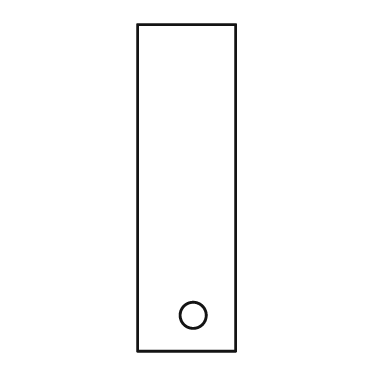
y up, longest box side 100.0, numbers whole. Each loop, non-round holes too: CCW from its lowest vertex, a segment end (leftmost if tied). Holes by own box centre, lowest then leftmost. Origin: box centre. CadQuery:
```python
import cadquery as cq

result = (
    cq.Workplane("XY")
    .moveTo(-15.0, -50.0)
    .lineTo(15.0, -50.0)
    .lineTo(15.0, 50.0)
    .lineTo(-15.0, 50.0)
    .close()
    .moveTo(2.0, -39.0)
    .circle(4.0)
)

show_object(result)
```